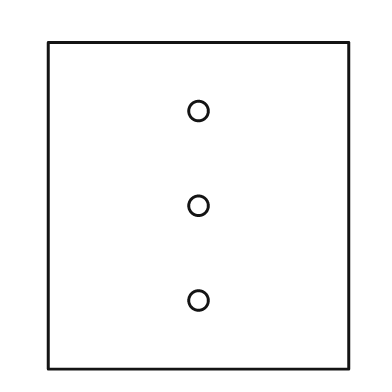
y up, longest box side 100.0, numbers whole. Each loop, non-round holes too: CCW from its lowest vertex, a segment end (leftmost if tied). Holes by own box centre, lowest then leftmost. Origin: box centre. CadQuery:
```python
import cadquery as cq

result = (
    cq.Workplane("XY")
    .moveTo(-46.0, -50.0)
    .lineTo(46.0, -50.0)
    .lineTo(46.0, 50.0)
    .lineTo(-46.0, 50.0)
    .close()
    .moveTo(0.0, -29.0)
    .circle(3.0)
    .moveTo(0.0, 0.0)
    .circle(3.0)
    .moveTo(0.0, 29.0)
    .circle(3.0)
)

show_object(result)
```